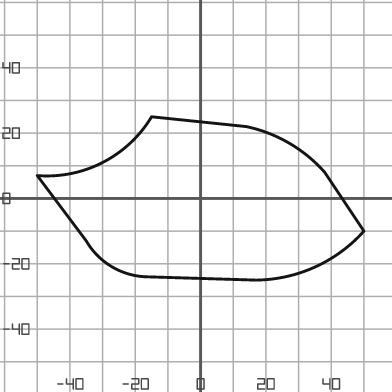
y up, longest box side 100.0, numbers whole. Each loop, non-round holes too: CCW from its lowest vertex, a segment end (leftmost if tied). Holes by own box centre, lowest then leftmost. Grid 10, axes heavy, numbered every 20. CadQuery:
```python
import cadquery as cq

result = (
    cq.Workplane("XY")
    .moveTo(17.0, -25.0)
    .threePointArc((35.0, -21.0), (50.0, -10.0))
    .lineTo(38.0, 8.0)
    .threePointArc((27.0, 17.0), (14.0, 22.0))
    .lineTo(-15.0, 25.0)
    .threePointArc((-30.0, 11.0), (-50.0, 7.0))
    .lineTo(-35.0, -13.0)
    .threePointArc((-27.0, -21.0), (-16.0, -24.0))
    .close()
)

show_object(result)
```